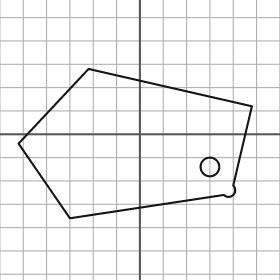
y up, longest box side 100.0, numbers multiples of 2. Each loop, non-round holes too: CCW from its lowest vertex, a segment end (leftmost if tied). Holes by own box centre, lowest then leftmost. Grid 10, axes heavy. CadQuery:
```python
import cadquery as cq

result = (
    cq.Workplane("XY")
    .moveTo(-30.0, -36.0)
    .lineTo(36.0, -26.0)
    .threePointArc((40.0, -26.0), (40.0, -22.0))
    .lineTo(48.0, 12.0)
    .lineTo(-22.0, 28.0)
    .lineTo(-52.0, -4.0)
    .close()
    .moveTo(30.0, -14.0)
    .circle(4.0)
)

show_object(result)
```